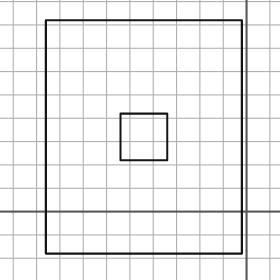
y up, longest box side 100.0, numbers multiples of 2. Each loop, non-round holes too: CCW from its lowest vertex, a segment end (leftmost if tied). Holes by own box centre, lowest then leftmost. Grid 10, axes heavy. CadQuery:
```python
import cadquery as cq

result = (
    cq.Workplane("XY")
    .moveTo(-86.0, -18.0)
    .lineTo(-2.0, -18.0)
    .lineTo(-2.0, 82.0)
    .lineTo(-86.0, 82.0)
    .close()
    .moveTo(-54.0, 22.0)
    .lineTo(-34.0, 22.0)
    .lineTo(-34.0, 42.0)
    .lineTo(-54.0, 42.0)
    .close()
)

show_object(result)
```